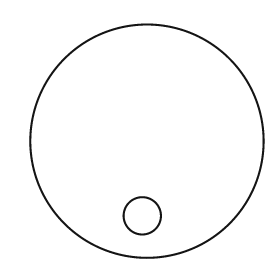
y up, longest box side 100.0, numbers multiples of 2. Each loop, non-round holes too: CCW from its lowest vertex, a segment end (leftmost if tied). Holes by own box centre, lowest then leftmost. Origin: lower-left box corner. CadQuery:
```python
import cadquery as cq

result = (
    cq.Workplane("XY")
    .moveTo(50.0, 50.0)
    .circle(50.0)
    .moveTo(48.0, 18.0)
    .circle(8.0)
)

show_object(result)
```